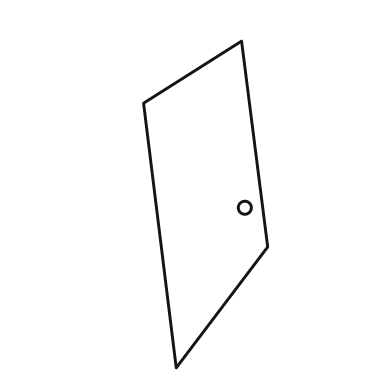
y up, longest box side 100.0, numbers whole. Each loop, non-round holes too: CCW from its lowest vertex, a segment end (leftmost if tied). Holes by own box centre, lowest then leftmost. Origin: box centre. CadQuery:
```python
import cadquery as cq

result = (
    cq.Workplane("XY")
    .moveTo(-9.0, -50.0)
    .lineTo(19.0, -13.0)
    .lineTo(11.0, 50.0)
    .lineTo(-19.0, 31.0)
    .close()
    .moveTo(12.0, -1.0)
    .circle(2.0)
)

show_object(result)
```